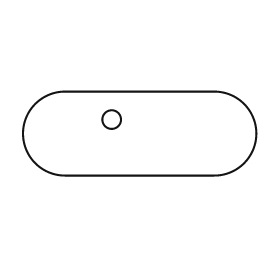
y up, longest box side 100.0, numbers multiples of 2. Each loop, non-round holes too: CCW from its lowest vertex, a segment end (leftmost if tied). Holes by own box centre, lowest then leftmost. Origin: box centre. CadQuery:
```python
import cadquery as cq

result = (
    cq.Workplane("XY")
    .moveTo(-32.0, -18.0)
    .lineTo(32.0, -18.0)
    .threePointArc((50.0, 0.0), (32.0, 18.0))
    .lineTo(-32.0, 18.0)
    .threePointArc((-50.0, 0.0), (-32.0, -18.0))
    .close()
    .moveTo(-12.0, 6.0)
    .circle(4.0)
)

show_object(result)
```